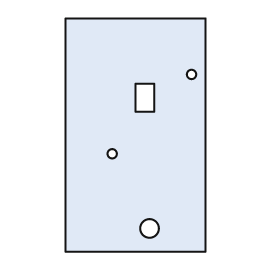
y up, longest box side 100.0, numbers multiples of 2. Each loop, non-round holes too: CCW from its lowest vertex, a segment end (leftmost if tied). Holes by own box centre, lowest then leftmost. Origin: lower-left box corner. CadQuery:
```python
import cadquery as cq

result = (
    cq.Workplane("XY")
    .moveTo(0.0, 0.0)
    .lineTo(60.0, 0.0)
    .lineTo(60.0, 100.0)
    .lineTo(0.0, 100.0)
    .close()
    .moveTo(36.0, 10.0)
    .circle(4.0)
    .moveTo(20.0, 42.0)
    .circle(2.0)
    .moveTo(30.0, 60.0)
    .lineTo(38.0, 60.0)
    .lineTo(38.0, 72.0)
    .lineTo(30.0, 72.0)
    .close()
    .moveTo(54.0, 76.0)
    .circle(2.0)
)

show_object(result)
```